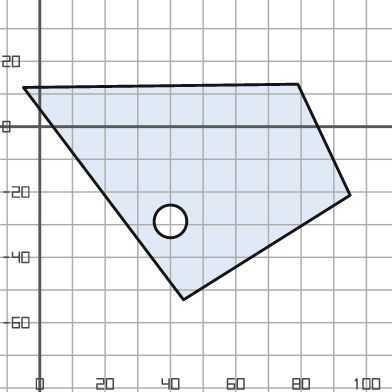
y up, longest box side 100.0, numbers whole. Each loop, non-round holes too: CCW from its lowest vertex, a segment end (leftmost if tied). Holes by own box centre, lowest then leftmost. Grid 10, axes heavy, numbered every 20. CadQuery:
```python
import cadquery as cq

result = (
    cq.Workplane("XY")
    .moveTo(44.0, -53.0)
    .lineTo(95.0, -21.0)
    .lineTo(79.0, 13.0)
    .lineTo(-5.0, 12.0)
    .close()
    .moveTo(40.0, -29.0)
    .circle(5.0)
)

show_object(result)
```